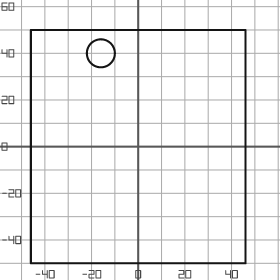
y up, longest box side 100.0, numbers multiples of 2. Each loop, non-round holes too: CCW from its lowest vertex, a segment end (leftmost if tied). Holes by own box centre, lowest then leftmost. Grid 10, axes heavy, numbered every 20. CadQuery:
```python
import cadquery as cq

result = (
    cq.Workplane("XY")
    .moveTo(-46.0, -50.0)
    .lineTo(46.0, -50.0)
    .lineTo(46.0, 50.0)
    .lineTo(-46.0, 50.0)
    .close()
    .moveTo(-16.0, 40.0)
    .circle(6.0)
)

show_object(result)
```